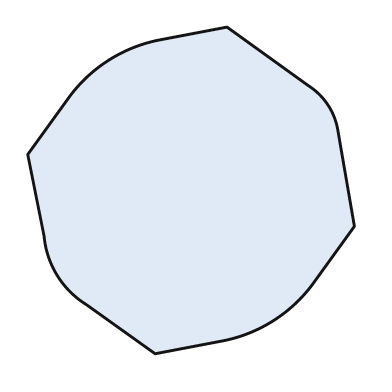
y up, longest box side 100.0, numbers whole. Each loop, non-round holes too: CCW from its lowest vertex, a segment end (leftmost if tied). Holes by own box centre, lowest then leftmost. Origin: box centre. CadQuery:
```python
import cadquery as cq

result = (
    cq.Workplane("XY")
    .moveTo(-11.0, -50.0)
    .lineTo(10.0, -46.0)
    .threePointArc((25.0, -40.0), (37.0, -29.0))
    .lineTo(50.0, -11.0)
    .lineTo(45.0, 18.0)
    .threePointArc((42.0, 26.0), (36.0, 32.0))
    .lineTo(11.0, 50.0)
    .lineTo(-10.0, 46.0)
    .threePointArc((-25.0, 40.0), (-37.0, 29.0))
    .lineTo(-50.0, 11.0)
    .lineTo(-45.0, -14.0)
    .threePointArc((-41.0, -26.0), (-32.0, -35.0))
    .close()
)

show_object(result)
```